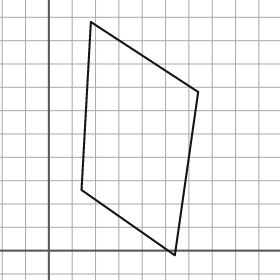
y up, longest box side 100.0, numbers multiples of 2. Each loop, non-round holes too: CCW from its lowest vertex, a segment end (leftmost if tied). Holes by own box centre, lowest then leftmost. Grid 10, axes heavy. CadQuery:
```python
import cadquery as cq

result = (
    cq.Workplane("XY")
    .moveTo(54.0, -2.0)
    .lineTo(64.0, 68.0)
    .lineTo(18.0, 98.0)
    .lineTo(14.0, 26.0)
    .close()
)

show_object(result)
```